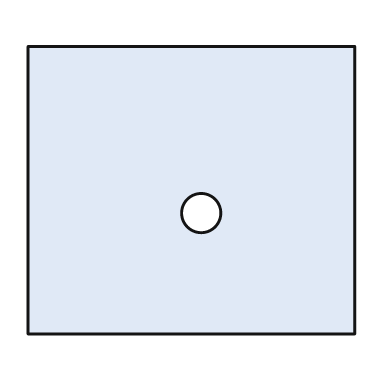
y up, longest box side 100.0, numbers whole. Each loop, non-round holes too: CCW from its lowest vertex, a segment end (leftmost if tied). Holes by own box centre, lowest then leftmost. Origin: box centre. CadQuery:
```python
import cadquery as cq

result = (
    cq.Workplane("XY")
    .moveTo(-50.0, -44.0)
    .lineTo(50.0, -44.0)
    .lineTo(50.0, 44.0)
    .lineTo(-50.0, 44.0)
    .close()
    .moveTo(3.0, -7.0)
    .circle(6.0)
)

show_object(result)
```